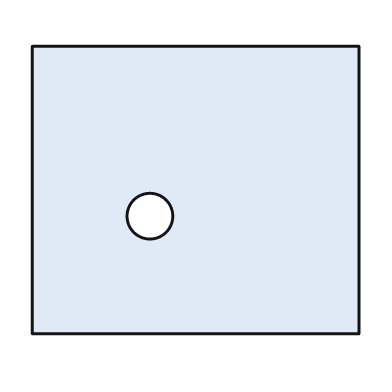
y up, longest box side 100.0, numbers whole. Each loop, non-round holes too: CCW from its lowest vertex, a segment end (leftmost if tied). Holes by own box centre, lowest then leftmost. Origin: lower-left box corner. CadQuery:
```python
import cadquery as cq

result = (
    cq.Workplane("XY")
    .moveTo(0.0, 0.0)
    .lineTo(100.0, 0.0)
    .lineTo(100.0, 88.0)
    .lineTo(0.0, 88.0)
    .close()
    .moveTo(36.0, 36.0)
    .circle(7.0)
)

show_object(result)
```